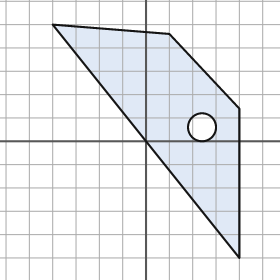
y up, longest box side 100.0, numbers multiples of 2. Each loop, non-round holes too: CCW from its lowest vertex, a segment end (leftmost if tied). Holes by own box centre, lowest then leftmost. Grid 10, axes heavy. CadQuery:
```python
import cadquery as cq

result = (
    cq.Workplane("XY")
    .moveTo(40.0, -50.0)
    .lineTo(40.0, 14.0)
    .lineTo(10.0, 46.0)
    .lineTo(-40.0, 50.0)
    .close()
    .moveTo(24.0, 6.0)
    .circle(6.0)
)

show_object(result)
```